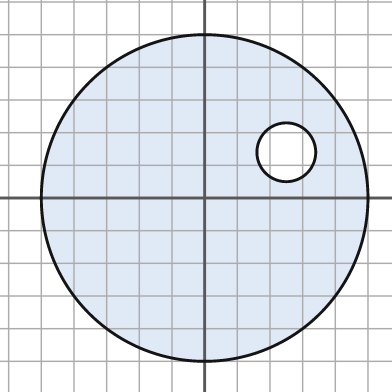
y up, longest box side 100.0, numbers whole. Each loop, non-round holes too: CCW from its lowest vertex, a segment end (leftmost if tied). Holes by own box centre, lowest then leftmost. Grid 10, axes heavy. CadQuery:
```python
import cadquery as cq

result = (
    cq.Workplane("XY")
    .moveTo(0.0, 0.0)
    .circle(50.0)
    .moveTo(25.0, 14.0)
    .circle(9.0)
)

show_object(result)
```